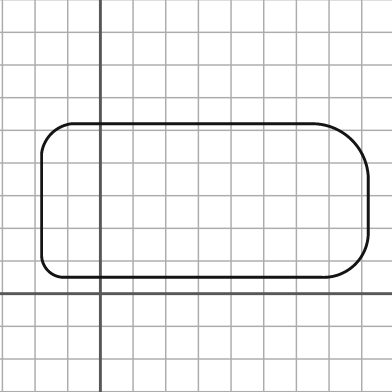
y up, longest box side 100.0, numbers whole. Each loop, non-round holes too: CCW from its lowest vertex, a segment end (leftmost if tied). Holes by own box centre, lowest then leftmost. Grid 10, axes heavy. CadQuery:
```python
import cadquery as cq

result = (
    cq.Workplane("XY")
    .moveTo(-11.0, 5.0)
    .lineTo(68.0, 5.0)
    .threePointArc((78.0, 9.0), (82.0, 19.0))
    .lineTo(82.0, 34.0)
    .threePointArc((77.0, 47.0), (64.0, 52.0))
    .lineTo(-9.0, 52.0)
    .threePointArc((-15.0, 49.0), (-18.0, 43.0))
    .lineTo(-18.0, 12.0)
    .threePointArc((-16.0, 7.0), (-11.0, 5.0))
    .close()
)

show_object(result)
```